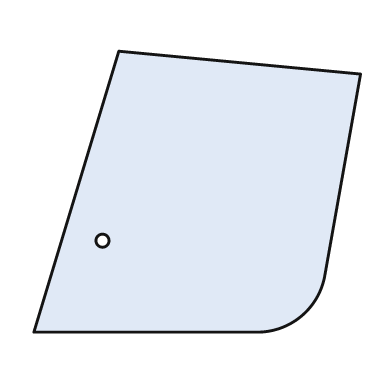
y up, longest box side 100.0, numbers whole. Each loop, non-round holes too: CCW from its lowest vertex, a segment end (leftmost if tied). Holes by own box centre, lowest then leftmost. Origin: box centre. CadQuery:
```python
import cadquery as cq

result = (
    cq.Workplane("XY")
    .moveTo(-50.0, -43.0)
    .lineTo(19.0, -43.0)
    .threePointArc((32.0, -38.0), (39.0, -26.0))
    .lineTo(50.0, 36.0)
    .lineTo(-24.0, 43.0)
    .close()
    .moveTo(-29.0, -15.0)
    .circle(2.0)
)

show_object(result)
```